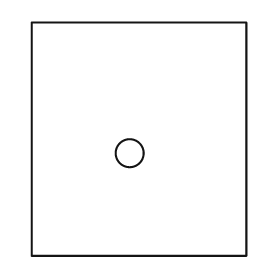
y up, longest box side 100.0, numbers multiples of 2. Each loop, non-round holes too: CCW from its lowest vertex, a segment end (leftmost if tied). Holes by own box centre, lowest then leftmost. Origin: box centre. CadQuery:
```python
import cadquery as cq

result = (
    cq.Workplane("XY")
    .moveTo(-46.0, -50.0)
    .lineTo(46.0, -50.0)
    .lineTo(46.0, 50.0)
    .lineTo(-46.0, 50.0)
    .close()
    .moveTo(-4.0, -6.0)
    .circle(6.0)
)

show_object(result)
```